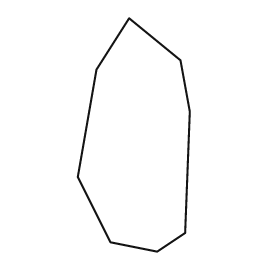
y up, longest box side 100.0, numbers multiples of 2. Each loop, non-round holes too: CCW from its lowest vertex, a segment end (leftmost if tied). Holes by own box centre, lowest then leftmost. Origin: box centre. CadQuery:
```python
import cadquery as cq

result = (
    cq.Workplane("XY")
    .moveTo(10.0, -50.0)
    .lineTo(22.0, -42.0)
    .lineTo(24.0, 10.0)
    .lineTo(20.0, 32.0)
    .lineTo(-2.0, 50.0)
    .lineTo(-16.0, 28.0)
    .lineTo(-24.0, -18.0)
    .lineTo(-10.0, -46.0)
    .close()
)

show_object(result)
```